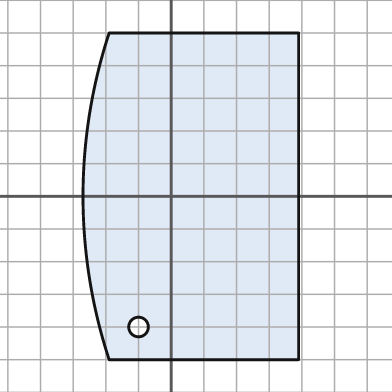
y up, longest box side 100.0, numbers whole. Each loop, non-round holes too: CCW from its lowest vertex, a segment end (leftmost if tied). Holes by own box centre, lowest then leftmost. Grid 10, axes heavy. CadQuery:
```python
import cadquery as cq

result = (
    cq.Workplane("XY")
    .moveTo(-19.0, -50.0)
    .lineTo(39.0, -50.0)
    .lineTo(39.0, 50.0)
    .lineTo(-19.0, 50.0)
    .threePointArc((-27.0, 0.0), (-19.0, -50.0))
    .close()
    .moveTo(-10.0, -40.0)
    .circle(3.0)
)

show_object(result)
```